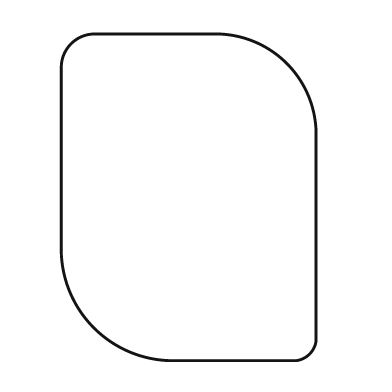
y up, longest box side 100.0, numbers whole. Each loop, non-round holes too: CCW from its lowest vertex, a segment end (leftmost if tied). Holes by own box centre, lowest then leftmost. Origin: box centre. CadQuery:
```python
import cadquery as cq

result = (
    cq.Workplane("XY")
    .moveTo(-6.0, -50.0)
    .lineTo(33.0, -50.0)
    .threePointArc((37.0, -48.0), (39.0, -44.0))
    .lineTo(39.0, 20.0)
    .threePointArc((30.0, 41.0), (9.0, 50.0))
    .lineTo(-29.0, 50.0)
    .threePointArc((-36.0, 47.0), (-39.0, 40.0))
    .lineTo(-39.0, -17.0)
    .threePointArc((-29.0, -40.0), (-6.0, -50.0))
    .close()
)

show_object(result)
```